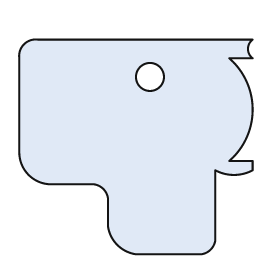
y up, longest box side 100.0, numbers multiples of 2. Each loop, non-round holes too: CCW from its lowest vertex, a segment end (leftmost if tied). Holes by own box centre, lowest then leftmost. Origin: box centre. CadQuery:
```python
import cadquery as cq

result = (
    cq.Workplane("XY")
    .moveTo(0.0, -46.0)
    .lineTo(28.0, -46.0)
    .threePointArc((32.0, -44.0), (34.0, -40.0))
    .lineTo(34.0, -10.0)
    .threePointArc((42.0, -12.0), (50.0, -10.0))
    .lineTo(50.0, -6.0)
    .lineTo(40.0, -6.0)
    .threePointArc((50.0, 16.0), (40.0, 38.0))
    .lineTo(50.0, 38.0)
    .threePointArc((48.0, 42.0), (50.0, 46.0))
    .lineTo(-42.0, 46.0)
    .threePointArc((-48.0, 44.0), (-50.0, 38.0))
    .lineTo(-50.0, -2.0)
    .threePointArc((-46.0, -12.0), (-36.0, -16.0))
    .lineTo(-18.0, -16.0)
    .threePointArc((-14.0, -18.0), (-12.0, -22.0))
    .lineTo(-12.0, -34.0)
    .threePointArc((-8.0, -42.0), (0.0, -46.0))
    .close()
    .moveTo(6.0, 30.0)
    .circle(6.0)
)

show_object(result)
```